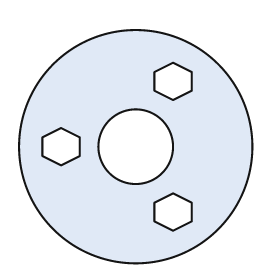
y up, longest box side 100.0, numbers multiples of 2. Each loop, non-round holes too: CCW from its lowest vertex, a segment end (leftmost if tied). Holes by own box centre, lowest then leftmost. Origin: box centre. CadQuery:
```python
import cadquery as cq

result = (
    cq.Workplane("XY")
    .moveTo(0.0, 0.0)
    .circle(50.0)
    .moveTo(16.0, -36.0)
    .lineTo(24.0, -32.0)
    .lineTo(24.0, -24.0)
    .lineTo(16.0, -20.0)
    .lineTo(8.0, -24.0)
    .lineTo(8.0, -32.0)
    .close()
    .moveTo(-32.0, -8.0)
    .lineTo(-24.0, -4.0)
    .lineTo(-24.0, 4.0)
    .lineTo(-32.0, 8.0)
    .lineTo(-40.0, 4.0)
    .lineTo(-40.0, -4.0)
    .close()
    .moveTo(0.0, 0.0)
    .circle(16.0)
    .moveTo(16.0, 20.0)
    .lineTo(24.0, 24.0)
    .lineTo(24.0, 32.0)
    .lineTo(16.0, 36.0)
    .lineTo(8.0, 32.0)
    .lineTo(8.0, 24.0)
    .close()
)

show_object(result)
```